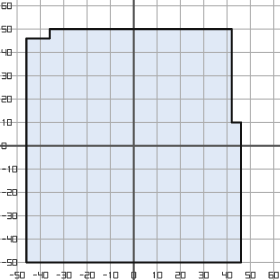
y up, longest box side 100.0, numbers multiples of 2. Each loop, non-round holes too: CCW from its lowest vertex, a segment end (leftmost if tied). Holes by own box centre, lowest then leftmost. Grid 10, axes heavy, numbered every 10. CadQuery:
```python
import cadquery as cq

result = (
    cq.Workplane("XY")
    .moveTo(-46.0, -50.0)
    .lineTo(46.0, -50.0)
    .lineTo(46.0, 10.0)
    .lineTo(42.0, 10.0)
    .lineTo(42.0, 50.0)
    .lineTo(-36.0, 50.0)
    .lineTo(-36.0, 46.0)
    .lineTo(-46.0, 46.0)
    .close()
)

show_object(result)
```